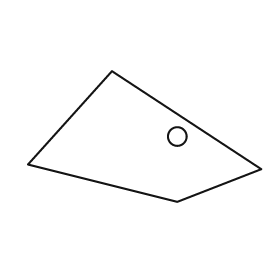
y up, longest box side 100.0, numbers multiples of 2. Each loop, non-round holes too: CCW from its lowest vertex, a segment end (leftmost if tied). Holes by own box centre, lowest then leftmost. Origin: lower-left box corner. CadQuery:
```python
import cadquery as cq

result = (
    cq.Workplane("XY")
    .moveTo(64.0, 0.0)
    .lineTo(100.0, 14.0)
    .lineTo(36.0, 56.0)
    .lineTo(0.0, 16.0)
    .close()
    .moveTo(64.0, 28.0)
    .circle(4.0)
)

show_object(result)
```